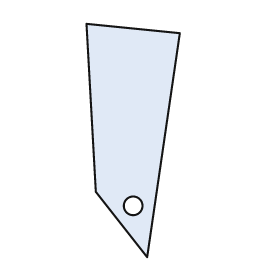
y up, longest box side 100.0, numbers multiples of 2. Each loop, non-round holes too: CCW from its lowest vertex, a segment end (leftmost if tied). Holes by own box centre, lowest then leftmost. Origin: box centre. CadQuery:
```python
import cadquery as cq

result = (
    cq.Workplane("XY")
    .moveTo(6.0, -50.0)
    .lineTo(20.0, 46.0)
    .lineTo(-20.0, 50.0)
    .lineTo(-16.0, -22.0)
    .close()
    .moveTo(0.0, -28.0)
    .circle(4.0)
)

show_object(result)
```